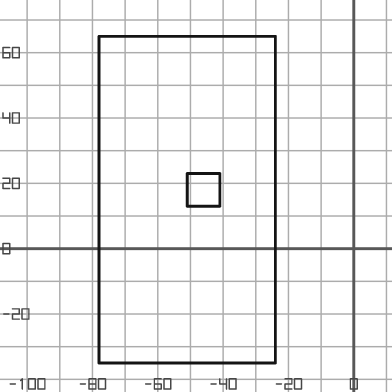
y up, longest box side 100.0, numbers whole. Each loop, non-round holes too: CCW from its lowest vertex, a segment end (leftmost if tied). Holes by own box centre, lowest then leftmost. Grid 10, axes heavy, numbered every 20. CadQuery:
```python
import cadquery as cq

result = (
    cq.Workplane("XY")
    .moveTo(-78.0, -35.0)
    .lineTo(-24.0, -35.0)
    .lineTo(-24.0, 65.0)
    .lineTo(-78.0, 65.0)
    .close()
    .moveTo(-51.0, 13.0)
    .lineTo(-41.0, 13.0)
    .lineTo(-41.0, 23.0)
    .lineTo(-51.0, 23.0)
    .close()
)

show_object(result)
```